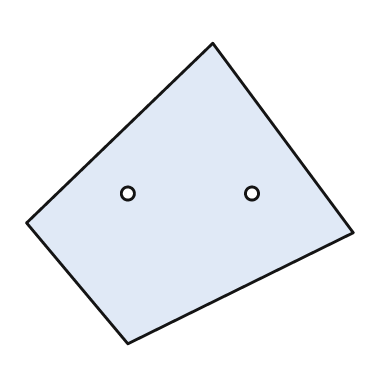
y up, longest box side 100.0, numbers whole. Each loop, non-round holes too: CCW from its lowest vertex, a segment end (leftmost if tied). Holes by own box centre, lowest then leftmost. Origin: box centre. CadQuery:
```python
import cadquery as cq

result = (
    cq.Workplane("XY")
    .moveTo(-19.0, -46.0)
    .lineTo(50.0, -12.0)
    .lineTo(7.0, 46.0)
    .lineTo(-50.0, -9.0)
    .close()
    .moveTo(-19.0, 0.0)
    .circle(2.0)
    .moveTo(19.0, 0.0)
    .circle(2.0)
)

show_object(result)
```